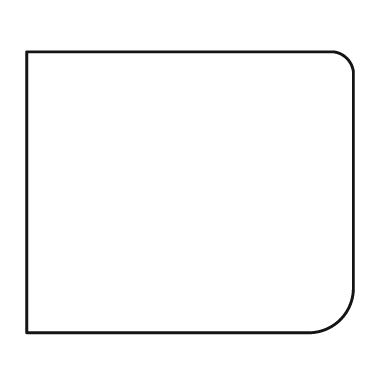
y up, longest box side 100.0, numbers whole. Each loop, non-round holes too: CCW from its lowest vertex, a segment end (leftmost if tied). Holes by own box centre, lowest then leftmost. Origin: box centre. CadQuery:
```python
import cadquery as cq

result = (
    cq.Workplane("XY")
    .moveTo(-50.0, -43.0)
    .lineTo(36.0, -43.0)
    .threePointArc((46.0, -39.0), (50.0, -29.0))
    .lineTo(50.0, 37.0)
    .threePointArc((48.0, 41.0), (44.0, 43.0))
    .lineTo(-50.0, 43.0)
    .close()
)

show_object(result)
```